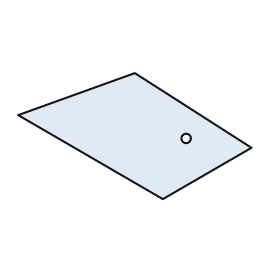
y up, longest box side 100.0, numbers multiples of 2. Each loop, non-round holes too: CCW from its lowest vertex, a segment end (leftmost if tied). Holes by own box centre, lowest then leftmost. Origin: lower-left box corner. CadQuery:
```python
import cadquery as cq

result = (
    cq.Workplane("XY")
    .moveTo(62.0, 0.0)
    .lineTo(100.0, 22.0)
    .lineTo(50.0, 54.0)
    .lineTo(0.0, 36.0)
    .close()
    .moveTo(72.0, 26.0)
    .circle(2.0)
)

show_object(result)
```